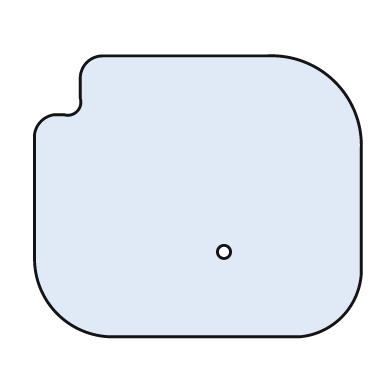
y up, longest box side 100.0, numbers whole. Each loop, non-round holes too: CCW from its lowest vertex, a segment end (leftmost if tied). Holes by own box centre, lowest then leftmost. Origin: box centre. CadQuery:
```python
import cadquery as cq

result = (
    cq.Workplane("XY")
    .moveTo(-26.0, -43.0)
    .lineTo(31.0, -43.0)
    .threePointArc((44.0, -37.0), (50.0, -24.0))
    .lineTo(50.0, 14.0)
    .threePointArc((42.0, 35.0), (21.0, 43.0))
    .lineTo(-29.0, 43.0)
    .threePointArc((-34.0, 41.0), (-36.0, 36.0))
    .lineTo(-36.0, 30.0)
    .threePointArc((-37.0, 26.0), (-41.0, 25.0))
    .lineTo(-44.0, 25.0)
    .threePointArc((-48.0, 23.0), (-50.0, 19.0))
    .lineTo(-50.0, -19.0)
    .threePointArc((-43.0, -36.0), (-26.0, -43.0))
    .close()
    .moveTo(8.0, -17.0)
    .circle(2.0)
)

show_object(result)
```